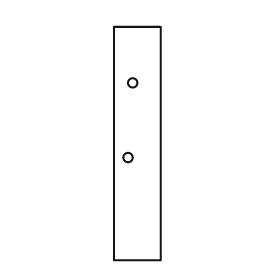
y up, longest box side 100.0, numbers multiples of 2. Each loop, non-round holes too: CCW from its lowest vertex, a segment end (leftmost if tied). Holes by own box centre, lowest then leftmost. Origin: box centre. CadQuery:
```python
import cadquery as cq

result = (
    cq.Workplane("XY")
    .moveTo(-10.0, -50.0)
    .lineTo(10.0, -50.0)
    .lineTo(10.0, 50.0)
    .lineTo(-10.0, 50.0)
    .close()
    .moveTo(-4.0, -6.0)
    .circle(2.0)
    .moveTo(-2.0, 26.0)
    .circle(2.0)
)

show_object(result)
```